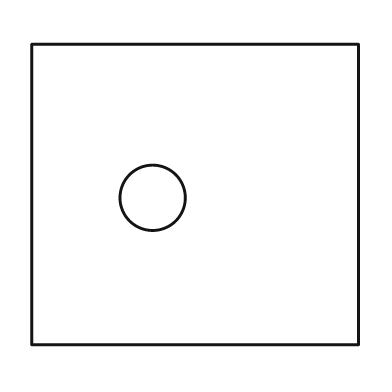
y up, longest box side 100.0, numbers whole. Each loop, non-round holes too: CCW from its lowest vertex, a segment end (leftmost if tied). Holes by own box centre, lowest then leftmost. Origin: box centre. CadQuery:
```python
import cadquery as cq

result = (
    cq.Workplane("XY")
    .moveTo(-50.0, -46.0)
    .lineTo(50.0, -46.0)
    .lineTo(50.0, 46.0)
    .lineTo(-50.0, 46.0)
    .close()
    .moveTo(-13.0, -1.0)
    .circle(10.0)
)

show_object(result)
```